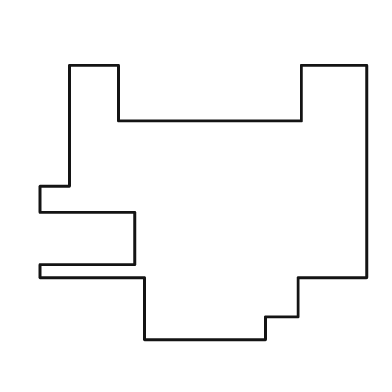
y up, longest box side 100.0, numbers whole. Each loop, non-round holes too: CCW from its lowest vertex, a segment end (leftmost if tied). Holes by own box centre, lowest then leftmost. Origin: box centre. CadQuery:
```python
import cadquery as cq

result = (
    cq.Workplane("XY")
    .moveTo(-18.0, -42.0)
    .lineTo(19.0, -42.0)
    .lineTo(19.0, -35.0)
    .lineTo(29.0, -35.0)
    .lineTo(29.0, -23.0)
    .lineTo(50.0, -23.0)
    .lineTo(50.0, 42.0)
    .lineTo(30.0, 42.0)
    .lineTo(30.0, 25.0)
    .lineTo(-26.0, 25.0)
    .lineTo(-26.0, 42.0)
    .lineTo(-41.0, 42.0)
    .lineTo(-41.0, 5.0)
    .lineTo(-50.0, 5.0)
    .lineTo(-50.0, -3.0)
    .lineTo(-21.0, -3.0)
    .lineTo(-21.0, -19.0)
    .lineTo(-50.0, -19.0)
    .lineTo(-50.0, -23.0)
    .lineTo(-18.0, -23.0)
    .close()
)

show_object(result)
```